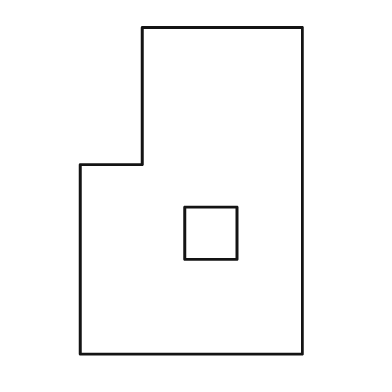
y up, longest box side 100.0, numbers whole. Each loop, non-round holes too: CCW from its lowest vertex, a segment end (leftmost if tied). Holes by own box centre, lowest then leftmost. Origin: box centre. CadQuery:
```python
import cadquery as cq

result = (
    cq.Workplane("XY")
    .moveTo(-34.0, -50.0)
    .lineTo(34.0, -50.0)
    .lineTo(34.0, 50.0)
    .lineTo(-15.0, 50.0)
    .lineTo(-15.0, 8.0)
    .lineTo(-34.0, 8.0)
    .close()
    .moveTo(-2.0, -21.0)
    .lineTo(14.0, -21.0)
    .lineTo(14.0, -5.0)
    .lineTo(-2.0, -5.0)
    .close()
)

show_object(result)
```